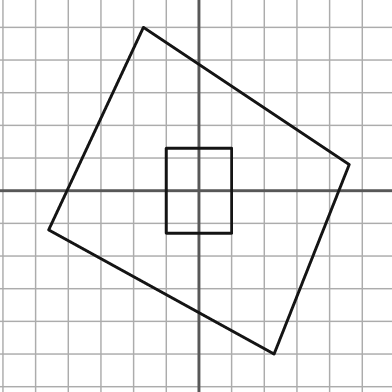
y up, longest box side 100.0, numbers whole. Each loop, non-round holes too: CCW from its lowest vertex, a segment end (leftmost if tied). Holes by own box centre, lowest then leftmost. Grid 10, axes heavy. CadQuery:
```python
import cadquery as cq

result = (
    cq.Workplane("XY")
    .moveTo(23.0, -50.0)
    .lineTo(46.0, 8.0)
    .lineTo(-17.0, 50.0)
    .lineTo(-46.0, -12.0)
    .close()
    .moveTo(-10.0, -13.0)
    .lineTo(10.0, -13.0)
    .lineTo(10.0, 13.0)
    .lineTo(-10.0, 13.0)
    .close()
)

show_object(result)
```